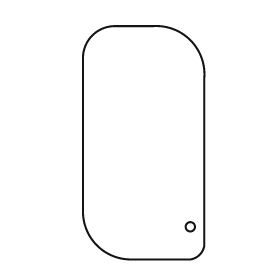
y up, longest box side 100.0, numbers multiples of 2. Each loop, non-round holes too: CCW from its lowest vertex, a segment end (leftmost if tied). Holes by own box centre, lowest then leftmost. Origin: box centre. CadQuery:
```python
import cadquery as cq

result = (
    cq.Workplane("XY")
    .moveTo(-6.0, -50.0)
    .lineTo(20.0, -50.0)
    .threePointArc((24.0, -48.0), (26.0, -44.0))
    .lineTo(26.0, 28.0)
    .threePointArc((20.0, 44.0), (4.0, 50.0))
    .lineTo(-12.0, 50.0)
    .threePointArc((-22.0, 46.0), (-26.0, 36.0))
    .lineTo(-26.0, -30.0)
    .threePointArc((-20.0, -44.0), (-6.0, -50.0))
    .close()
    .moveTo(20.0, -36.0)
    .circle(2.0)
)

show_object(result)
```